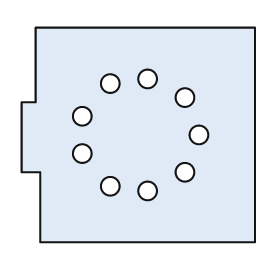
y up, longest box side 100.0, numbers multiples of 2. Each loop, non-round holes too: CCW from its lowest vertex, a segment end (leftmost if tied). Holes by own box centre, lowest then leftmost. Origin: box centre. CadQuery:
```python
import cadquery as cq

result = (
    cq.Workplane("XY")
    .moveTo(-42.0, -46.0)
    .lineTo(50.0, -46.0)
    .lineTo(50.0, 46.0)
    .lineTo(-44.0, 46.0)
    .lineTo(-44.0, 14.0)
    .lineTo(-50.0, 14.0)
    .lineTo(-50.0, -16.0)
    .lineTo(-42.0, -16.0)
    .close()
    .moveTo(4.0, -24.0)
    .circle(4.0)
    .moveTo(-12.0, -22.0)
    .circle(4.0)
    .moveTo(20.0, -16.0)
    .circle(4.0)
    .moveTo(-24.0, -8.0)
    .circle(4.0)
    .moveTo(26.0, 0.0)
    .circle(4.0)
    .moveTo(-24.0, 8.0)
    .circle(4.0)
    .moveTo(20.0, 16.0)
    .circle(4.0)
    .moveTo(-12.0, 22.0)
    .circle(4.0)
    .moveTo(4.0, 24.0)
    .circle(4.0)
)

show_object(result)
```